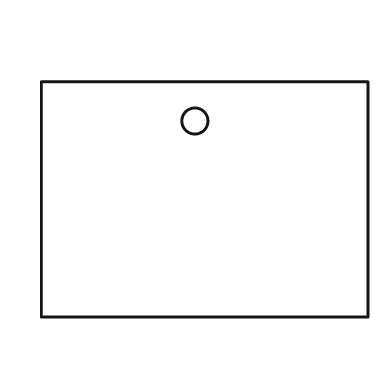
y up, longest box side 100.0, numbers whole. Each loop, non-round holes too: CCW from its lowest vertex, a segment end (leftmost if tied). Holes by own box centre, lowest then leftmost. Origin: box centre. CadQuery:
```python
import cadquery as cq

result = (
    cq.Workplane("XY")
    .moveTo(-50.0, -36.0)
    .lineTo(50.0, -36.0)
    .lineTo(50.0, 36.0)
    .lineTo(-50.0, 36.0)
    .close()
    .moveTo(-3.0, 24.0)
    .circle(4.0)
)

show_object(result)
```